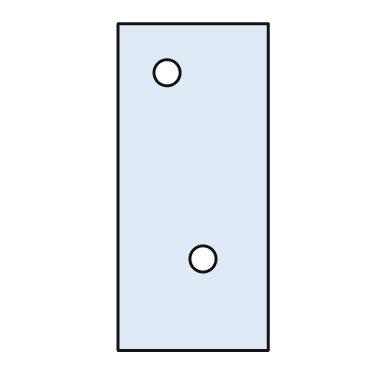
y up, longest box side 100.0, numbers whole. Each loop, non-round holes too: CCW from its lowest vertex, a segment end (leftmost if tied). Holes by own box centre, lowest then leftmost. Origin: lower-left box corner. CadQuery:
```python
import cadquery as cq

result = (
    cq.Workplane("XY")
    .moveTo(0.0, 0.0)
    .lineTo(46.0, 0.0)
    .lineTo(46.0, 100.0)
    .lineTo(0.0, 100.0)
    .close()
    .moveTo(26.0, 28.0)
    .circle(4.0)
    .moveTo(15.0, 85.0)
    .circle(4.0)
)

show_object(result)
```